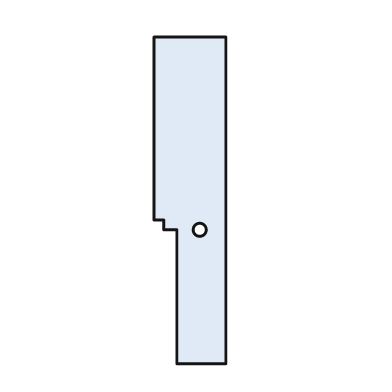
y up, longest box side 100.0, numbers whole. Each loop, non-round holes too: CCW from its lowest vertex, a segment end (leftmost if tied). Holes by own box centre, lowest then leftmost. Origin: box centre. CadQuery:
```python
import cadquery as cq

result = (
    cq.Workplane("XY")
    .moveTo(-4.0, -50.0)
    .lineTo(11.0, -50.0)
    .lineTo(11.0, 50.0)
    .lineTo(-11.0, 50.0)
    .lineTo(-11.0, -6.0)
    .lineTo(-8.0, -6.0)
    .lineTo(-8.0, -9.0)
    .lineTo(-4.0, -9.0)
    .close()
    .moveTo(3.0, -9.0)
    .circle(2.0)
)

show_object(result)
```